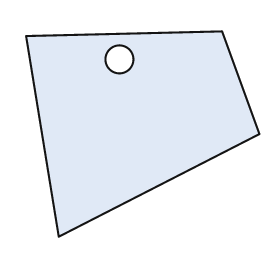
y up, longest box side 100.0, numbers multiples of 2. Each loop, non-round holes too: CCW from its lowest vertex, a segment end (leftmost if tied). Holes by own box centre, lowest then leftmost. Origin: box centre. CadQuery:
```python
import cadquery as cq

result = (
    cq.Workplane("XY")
    .moveTo(-36.0, -44.0)
    .lineTo(50.0, 0.0)
    .lineTo(34.0, 44.0)
    .lineTo(-50.0, 42.0)
    .close()
    .moveTo(-10.0, 32.0)
    .circle(6.0)
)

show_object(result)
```